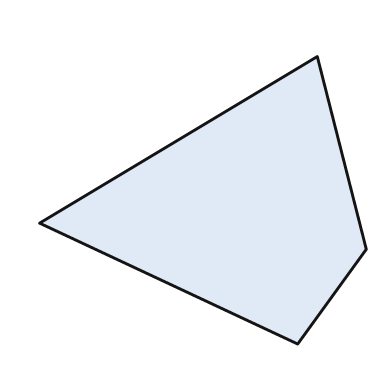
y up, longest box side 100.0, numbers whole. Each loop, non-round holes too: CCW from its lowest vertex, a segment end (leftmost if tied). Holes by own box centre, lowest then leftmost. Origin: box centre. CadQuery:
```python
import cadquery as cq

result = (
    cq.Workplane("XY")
    .moveTo(29.0, -44.0)
    .lineTo(50.0, -15.0)
    .lineTo(35.0, 44.0)
    .lineTo(-50.0, -7.0)
    .close()
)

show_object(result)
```